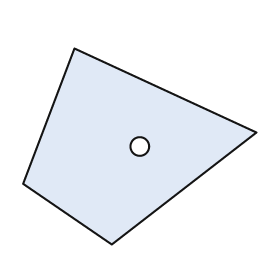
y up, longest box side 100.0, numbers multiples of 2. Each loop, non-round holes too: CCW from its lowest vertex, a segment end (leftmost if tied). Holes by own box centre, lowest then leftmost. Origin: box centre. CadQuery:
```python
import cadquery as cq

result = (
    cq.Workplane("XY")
    .moveTo(-12.0, -42.0)
    .lineTo(50.0, 6.0)
    .lineTo(-28.0, 42.0)
    .lineTo(-50.0, -16.0)
    .close()
    .moveTo(0.0, 0.0)
    .circle(4.0)
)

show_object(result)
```